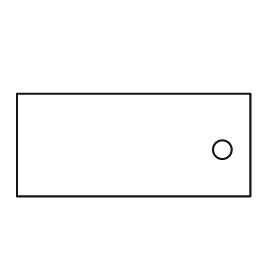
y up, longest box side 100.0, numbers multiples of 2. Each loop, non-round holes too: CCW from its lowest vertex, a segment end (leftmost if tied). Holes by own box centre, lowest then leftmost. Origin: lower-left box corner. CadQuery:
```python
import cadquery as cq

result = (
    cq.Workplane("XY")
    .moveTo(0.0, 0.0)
    .lineTo(100.0, 0.0)
    .lineTo(100.0, 44.0)
    .lineTo(0.0, 44.0)
    .close()
    .moveTo(88.0, 20.0)
    .circle(4.0)
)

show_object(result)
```